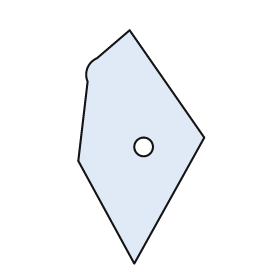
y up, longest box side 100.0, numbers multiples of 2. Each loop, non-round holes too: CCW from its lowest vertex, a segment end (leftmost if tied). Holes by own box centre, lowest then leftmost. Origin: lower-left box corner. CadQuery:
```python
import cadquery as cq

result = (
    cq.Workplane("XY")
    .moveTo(24.0, 0.0)
    .lineTo(54.0, 54.0)
    .lineTo(22.0, 100.0)
    .lineTo(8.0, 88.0)
    .threePointArc((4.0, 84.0), (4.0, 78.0))
    .lineTo(0.0, 44.0)
    .close()
    .moveTo(28.0, 50.0)
    .circle(4.0)
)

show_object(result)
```